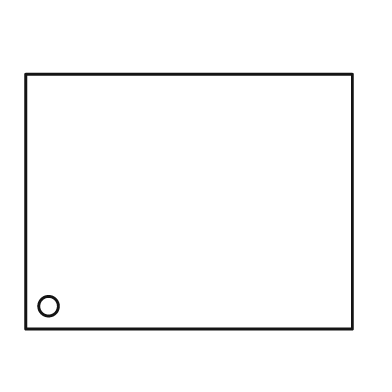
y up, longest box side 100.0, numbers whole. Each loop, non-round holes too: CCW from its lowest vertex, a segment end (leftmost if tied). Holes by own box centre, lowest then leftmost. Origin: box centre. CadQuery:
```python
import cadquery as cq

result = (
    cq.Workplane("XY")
    .moveTo(-50.0, -39.0)
    .lineTo(50.0, -39.0)
    .lineTo(50.0, 39.0)
    .lineTo(-50.0, 39.0)
    .close()
    .moveTo(-43.0, -32.0)
    .circle(3.0)
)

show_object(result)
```